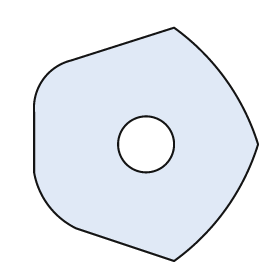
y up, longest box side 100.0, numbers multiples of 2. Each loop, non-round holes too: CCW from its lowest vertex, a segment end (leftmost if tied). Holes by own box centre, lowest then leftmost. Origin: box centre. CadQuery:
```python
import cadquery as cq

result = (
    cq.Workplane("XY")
    .moveTo(12.0, -50.0)
    .threePointArc((34.0, -28.0), (48.0, 0.0))
    .threePointArc((34.0, 28.0), (12.0, 50.0))
    .lineTo(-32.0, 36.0)
    .threePointArc((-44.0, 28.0), (-48.0, 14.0))
    .lineTo(-48.0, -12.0)
    .threePointArc((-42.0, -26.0), (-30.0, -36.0))
    .close()
    .moveTo(0.0, 0.0)
    .circle(12.0)
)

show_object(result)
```